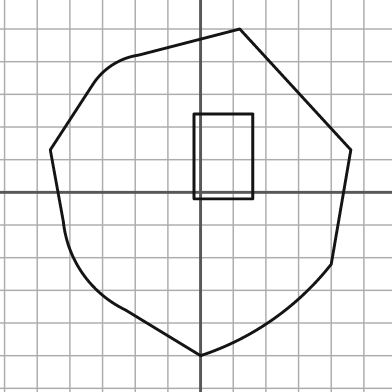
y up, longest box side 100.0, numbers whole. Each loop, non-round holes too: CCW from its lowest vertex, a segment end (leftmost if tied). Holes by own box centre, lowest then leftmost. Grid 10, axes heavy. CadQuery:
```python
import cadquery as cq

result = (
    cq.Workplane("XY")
    .moveTo(0.0, -50.0)
    .threePointArc((22.0, -39.0), (40.0, -22.0))
    .lineTo(46.0, 13.0)
    .lineTo(12.0, 50.0)
    .lineTo(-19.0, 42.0)
    .threePointArc((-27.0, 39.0), (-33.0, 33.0))
    .lineTo(-46.0, 13.0)
    .lineTo(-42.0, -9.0)
    .threePointArc((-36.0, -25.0), (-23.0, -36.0))
    .close()
    .moveTo(-2.0, -2.0)
    .lineTo(16.0, -2.0)
    .lineTo(16.0, 24.0)
    .lineTo(-2.0, 24.0)
    .close()
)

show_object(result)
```